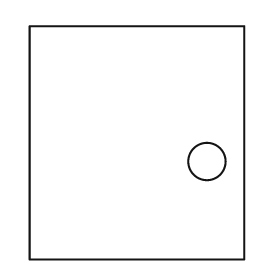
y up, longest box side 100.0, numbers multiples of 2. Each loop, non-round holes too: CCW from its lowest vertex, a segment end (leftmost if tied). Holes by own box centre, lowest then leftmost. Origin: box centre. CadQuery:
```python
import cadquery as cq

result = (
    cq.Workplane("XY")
    .moveTo(-46.0, -50.0)
    .lineTo(46.0, -50.0)
    .lineTo(46.0, 50.0)
    .lineTo(-46.0, 50.0)
    .close()
    .moveTo(30.0, -8.0)
    .circle(8.0)
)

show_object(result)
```